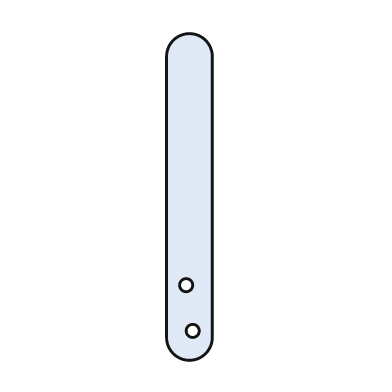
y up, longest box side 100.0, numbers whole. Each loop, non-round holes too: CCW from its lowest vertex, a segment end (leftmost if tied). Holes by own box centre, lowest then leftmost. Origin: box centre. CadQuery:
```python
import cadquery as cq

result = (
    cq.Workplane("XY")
    .moveTo(-7.0, -43.0)
    .threePointArc((0.0, -50.0), (7.0, -43.0))
    .lineTo(7.0, 43.0)
    .threePointArc((0.0, 50.0), (-7.0, 43.0))
    .close()
    .moveTo(1.0, -41.0)
    .circle(2.0)
    .moveTo(-1.0, -27.0)
    .circle(2.0)
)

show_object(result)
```